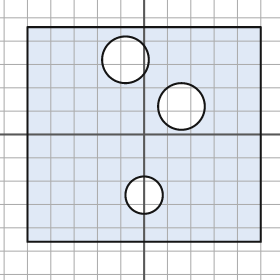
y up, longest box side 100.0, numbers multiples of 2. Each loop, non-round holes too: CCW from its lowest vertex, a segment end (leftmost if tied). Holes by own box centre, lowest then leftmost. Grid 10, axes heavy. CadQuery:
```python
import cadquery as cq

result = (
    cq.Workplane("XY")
    .moveTo(-50.0, -46.0)
    .lineTo(50.0, -46.0)
    .lineTo(50.0, 46.0)
    .lineTo(-50.0, 46.0)
    .close()
    .moveTo(0.0, -26.0)
    .circle(8.0)
    .moveTo(16.0, 12.0)
    .circle(10.0)
    .moveTo(-8.0, 32.0)
    .circle(10.0)
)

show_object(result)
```